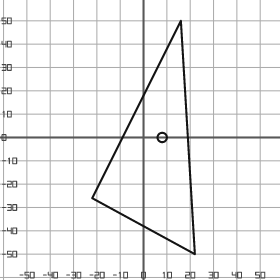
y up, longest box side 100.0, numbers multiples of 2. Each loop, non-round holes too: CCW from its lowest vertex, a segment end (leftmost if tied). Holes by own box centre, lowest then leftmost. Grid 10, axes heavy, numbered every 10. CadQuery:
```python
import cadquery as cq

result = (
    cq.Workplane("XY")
    .moveTo(22.0, -50.0)
    .lineTo(16.0, 50.0)
    .lineTo(-22.0, -26.0)
    .close()
    .moveTo(8.0, 0.0)
    .circle(2.0)
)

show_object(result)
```